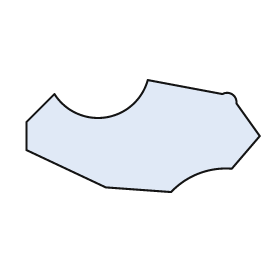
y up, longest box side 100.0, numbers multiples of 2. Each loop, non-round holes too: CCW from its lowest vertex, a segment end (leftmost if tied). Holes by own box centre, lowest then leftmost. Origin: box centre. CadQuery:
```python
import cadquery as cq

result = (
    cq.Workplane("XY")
    .moveTo(12.0, -24.0)
    .threePointArc((24.0, -16.0), (38.0, -14.0))
    .lineTo(50.0, 0.0)
    .lineTo(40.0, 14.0)
    .threePointArc((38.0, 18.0), (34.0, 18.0))
    .lineTo(2.0, 24.0)
    .threePointArc((-16.0, 8.0), (-38.0, 18.0))
    .lineTo(-50.0, 6.0)
    .lineTo(-50.0, -6.0)
    .lineTo(-16.0, -22.0)
    .close()
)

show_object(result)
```